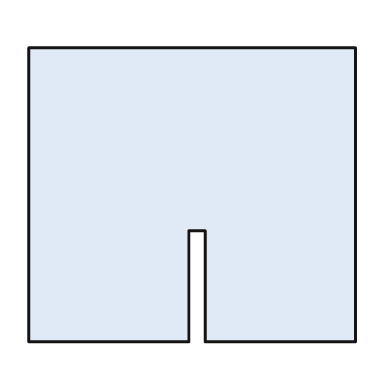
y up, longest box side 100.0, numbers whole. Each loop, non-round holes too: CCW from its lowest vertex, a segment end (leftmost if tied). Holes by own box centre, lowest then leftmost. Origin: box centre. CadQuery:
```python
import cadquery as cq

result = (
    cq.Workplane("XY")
    .moveTo(-50.0, -45.0)
    .lineTo(-1.0, -45.0)
    .lineTo(-1.0, -11.0)
    .lineTo(4.0, -11.0)
    .lineTo(4.0, -45.0)
    .lineTo(50.0, -45.0)
    .lineTo(50.0, 45.0)
    .lineTo(-50.0, 45.0)
    .close()
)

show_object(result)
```